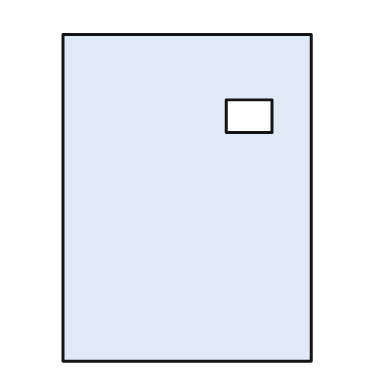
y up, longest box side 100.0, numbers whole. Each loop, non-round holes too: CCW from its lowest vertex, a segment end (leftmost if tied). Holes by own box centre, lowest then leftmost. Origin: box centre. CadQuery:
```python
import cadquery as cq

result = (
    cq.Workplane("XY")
    .moveTo(-38.0, -50.0)
    .lineTo(38.0, -50.0)
    .lineTo(38.0, 50.0)
    .lineTo(-38.0, 50.0)
    .close()
    .moveTo(12.0, 20.0)
    .lineTo(26.0, 20.0)
    .lineTo(26.0, 30.0)
    .lineTo(12.0, 30.0)
    .close()
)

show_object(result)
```